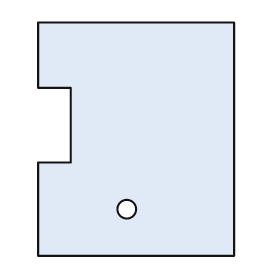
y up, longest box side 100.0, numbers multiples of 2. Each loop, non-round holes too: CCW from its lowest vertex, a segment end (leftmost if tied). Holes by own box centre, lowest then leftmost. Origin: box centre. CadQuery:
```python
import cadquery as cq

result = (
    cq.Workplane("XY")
    .moveTo(-42.0, -50.0)
    .lineTo(42.0, -50.0)
    .lineTo(42.0, 50.0)
    .lineTo(-42.0, 50.0)
    .lineTo(-42.0, 22.0)
    .lineTo(-28.0, 22.0)
    .lineTo(-28.0, -10.0)
    .lineTo(-42.0, -10.0)
    .close()
    .moveTo(-4.0, -30.0)
    .circle(4.0)
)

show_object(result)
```